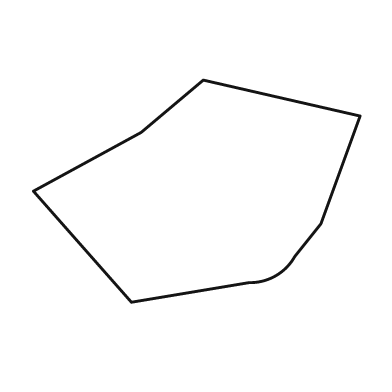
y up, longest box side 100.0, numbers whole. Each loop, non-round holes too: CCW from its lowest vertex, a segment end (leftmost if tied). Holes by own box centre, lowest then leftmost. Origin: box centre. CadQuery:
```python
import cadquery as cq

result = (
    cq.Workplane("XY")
    .moveTo(-20.0, -34.0)
    .lineTo(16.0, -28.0)
    .threePointArc((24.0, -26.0), (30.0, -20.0))
    .lineTo(38.0, -10.0)
    .lineTo(50.0, 23.0)
    .lineTo(2.0, 34.0)
    .lineTo(-17.0, 18.0)
    .lineTo(-50.0, 0.0)
    .close()
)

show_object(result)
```